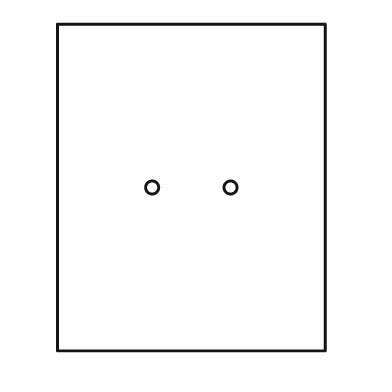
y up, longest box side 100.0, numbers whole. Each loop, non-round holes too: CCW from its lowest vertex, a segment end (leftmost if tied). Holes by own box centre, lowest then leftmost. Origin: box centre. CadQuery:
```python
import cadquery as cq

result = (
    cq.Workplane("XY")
    .moveTo(-41.0, -50.0)
    .lineTo(41.0, -50.0)
    .lineTo(41.0, 50.0)
    .lineTo(-41.0, 50.0)
    .close()
    .moveTo(-12.0, 0.0)
    .circle(2.0)
    .moveTo(12.0, 0.0)
    .circle(2.0)
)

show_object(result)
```